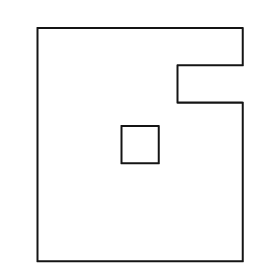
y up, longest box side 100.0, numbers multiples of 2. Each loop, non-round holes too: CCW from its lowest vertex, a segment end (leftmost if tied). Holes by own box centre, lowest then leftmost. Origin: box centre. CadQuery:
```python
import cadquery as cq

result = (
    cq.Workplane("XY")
    .moveTo(-44.0, -50.0)
    .lineTo(44.0, -50.0)
    .lineTo(44.0, 18.0)
    .lineTo(16.0, 18.0)
    .lineTo(16.0, 34.0)
    .lineTo(44.0, 34.0)
    .lineTo(44.0, 50.0)
    .lineTo(-44.0, 50.0)
    .close()
    .moveTo(-8.0, -8.0)
    .lineTo(8.0, -8.0)
    .lineTo(8.0, 8.0)
    .lineTo(-8.0, 8.0)
    .close()
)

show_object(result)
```